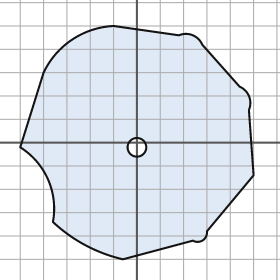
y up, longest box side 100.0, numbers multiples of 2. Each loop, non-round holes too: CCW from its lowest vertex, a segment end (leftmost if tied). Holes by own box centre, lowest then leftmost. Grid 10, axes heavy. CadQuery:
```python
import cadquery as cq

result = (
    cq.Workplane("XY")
    .moveTo(-6.0, -50.0)
    .lineTo(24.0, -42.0)
    .threePointArc((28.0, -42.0), (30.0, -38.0))
    .lineTo(50.0, -14.0)
    .lineTo(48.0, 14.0)
    .threePointArc((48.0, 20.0), (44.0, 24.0))
    .lineTo(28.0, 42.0)
    .threePointArc((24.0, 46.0), (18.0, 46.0))
    .lineTo(-10.0, 50.0)
    .threePointArc((-28.0, 44.0), (-40.0, 30.0))
    .lineTo(-50.0, -2.0)
    .threePointArc((-38.0, -16.0), (-36.0, -34.0))
    .threePointArc((-22.0, -44.0), (-6.0, -50.0))
    .close()
    .moveTo(0.0, -2.0)
    .circle(4.0)
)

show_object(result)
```